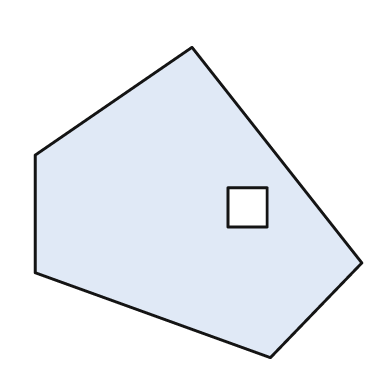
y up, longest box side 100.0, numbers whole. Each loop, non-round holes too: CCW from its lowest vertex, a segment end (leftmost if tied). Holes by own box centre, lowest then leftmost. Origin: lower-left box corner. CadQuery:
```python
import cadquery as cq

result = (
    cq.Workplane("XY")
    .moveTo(72.0, 0.0)
    .lineTo(100.0, 29.0)
    .lineTo(48.0, 95.0)
    .lineTo(0.0, 62.0)
    .lineTo(0.0, 26.0)
    .close()
    .moveTo(59.0, 40.0)
    .lineTo(71.0, 40.0)
    .lineTo(71.0, 52.0)
    .lineTo(59.0, 52.0)
    .close()
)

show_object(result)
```